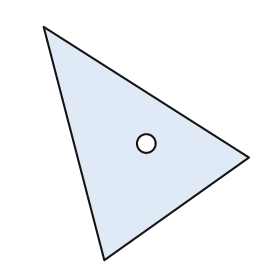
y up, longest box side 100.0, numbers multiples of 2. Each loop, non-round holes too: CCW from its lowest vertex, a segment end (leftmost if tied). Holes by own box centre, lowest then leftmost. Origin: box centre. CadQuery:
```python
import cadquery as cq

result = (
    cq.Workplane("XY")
    .moveTo(-18.0, -50.0)
    .lineTo(44.0, -6.0)
    .lineTo(-44.0, 50.0)
    .close()
    .moveTo(0.0, 0.0)
    .circle(4.0)
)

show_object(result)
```